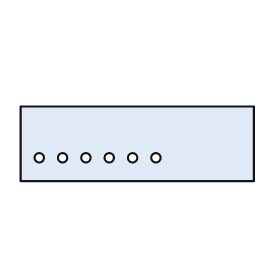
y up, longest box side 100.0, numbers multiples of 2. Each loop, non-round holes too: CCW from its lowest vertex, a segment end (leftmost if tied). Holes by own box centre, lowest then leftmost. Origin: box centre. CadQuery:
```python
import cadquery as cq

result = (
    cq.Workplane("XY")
    .moveTo(-50.0, -16.0)
    .lineTo(50.0, -16.0)
    .lineTo(50.0, 16.0)
    .lineTo(-50.0, 16.0)
    .close()
    .moveTo(-42.0, -6.0)
    .circle(2.0)
    .moveTo(-32.0, -6.0)
    .circle(2.0)
    .moveTo(-22.0, -6.0)
    .circle(2.0)
    .moveTo(-12.0, -6.0)
    .circle(2.0)
    .moveTo(-2.0, -6.0)
    .circle(2.0)
    .moveTo(8.0, -6.0)
    .circle(2.0)
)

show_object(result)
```